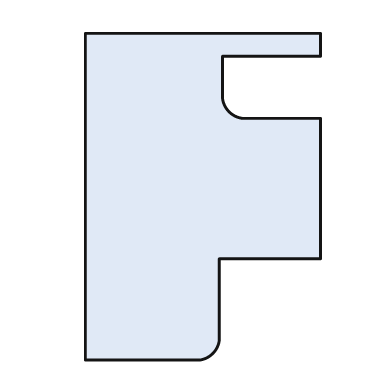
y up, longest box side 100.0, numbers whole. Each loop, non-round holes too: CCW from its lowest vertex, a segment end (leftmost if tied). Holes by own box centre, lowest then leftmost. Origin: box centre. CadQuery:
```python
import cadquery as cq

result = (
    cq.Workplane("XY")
    .moveTo(-36.0, -50.0)
    .lineTo(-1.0, -50.0)
    .threePointArc((3.0, -48.0), (5.0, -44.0))
    .lineTo(5.0, -19.0)
    .lineTo(36.0, -19.0)
    .lineTo(36.0, 24.0)
    .lineTo(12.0, 24.0)
    .threePointArc((8.0, 26.0), (6.0, 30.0))
    .lineTo(6.0, 43.0)
    .lineTo(36.0, 43.0)
    .lineTo(36.0, 50.0)
    .lineTo(-36.0, 50.0)
    .close()
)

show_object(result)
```